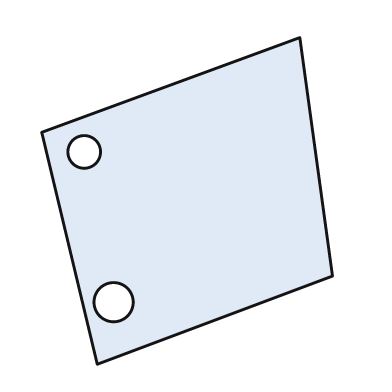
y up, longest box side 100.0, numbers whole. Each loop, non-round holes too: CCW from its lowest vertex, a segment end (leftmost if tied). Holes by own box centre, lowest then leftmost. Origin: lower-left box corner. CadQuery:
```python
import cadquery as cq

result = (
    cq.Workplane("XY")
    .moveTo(17.0, 0.0)
    .lineTo(89.0, 27.0)
    .lineTo(79.0, 100.0)
    .lineTo(0.0, 71.0)
    .close()
    .moveTo(22.0, 19.0)
    .circle(6.0)
    .moveTo(13.0, 65.0)
    .circle(5.0)
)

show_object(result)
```